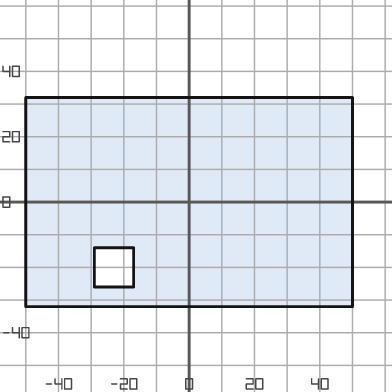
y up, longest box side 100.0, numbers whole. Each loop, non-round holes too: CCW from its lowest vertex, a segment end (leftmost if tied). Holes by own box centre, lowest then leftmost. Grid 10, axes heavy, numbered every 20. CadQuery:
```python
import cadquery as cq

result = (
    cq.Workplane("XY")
    .moveTo(-50.0, -32.0)
    .lineTo(50.0, -32.0)
    .lineTo(50.0, 32.0)
    .lineTo(-50.0, 32.0)
    .close()
    .moveTo(-29.0, -26.0)
    .lineTo(-17.0, -26.0)
    .lineTo(-17.0, -14.0)
    .lineTo(-29.0, -14.0)
    .close()
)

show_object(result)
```